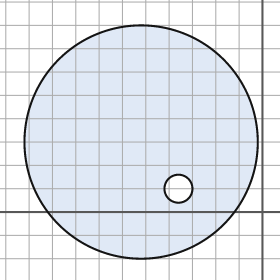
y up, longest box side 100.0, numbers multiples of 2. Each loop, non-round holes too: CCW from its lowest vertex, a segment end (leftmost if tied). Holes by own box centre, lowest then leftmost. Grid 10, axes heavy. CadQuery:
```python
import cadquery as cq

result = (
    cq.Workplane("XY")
    .moveTo(-52.0, 30.0)
    .circle(50.0)
    .moveTo(-36.0, 10.0)
    .circle(6.0)
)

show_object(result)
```